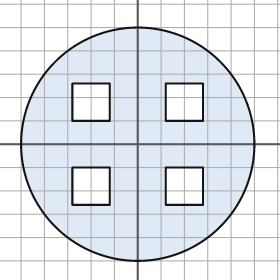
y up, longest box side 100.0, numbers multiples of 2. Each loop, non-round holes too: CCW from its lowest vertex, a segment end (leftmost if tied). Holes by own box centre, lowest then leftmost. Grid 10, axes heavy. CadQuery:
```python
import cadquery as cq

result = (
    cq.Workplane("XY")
    .moveTo(0.0, 0.0)
    .circle(50.0)
    .moveTo(-28.0, -26.0)
    .lineTo(-12.0, -26.0)
    .lineTo(-12.0, -10.0)
    .lineTo(-28.0, -10.0)
    .close()
    .moveTo(12.0, -26.0)
    .lineTo(28.0, -26.0)
    .lineTo(28.0, -10.0)
    .lineTo(12.0, -10.0)
    .close()
    .moveTo(-28.0, 10.0)
    .lineTo(-12.0, 10.0)
    .lineTo(-12.0, 26.0)
    .lineTo(-28.0, 26.0)
    .close()
    .moveTo(12.0, 10.0)
    .lineTo(28.0, 10.0)
    .lineTo(28.0, 26.0)
    .lineTo(12.0, 26.0)
    .close()
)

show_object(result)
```